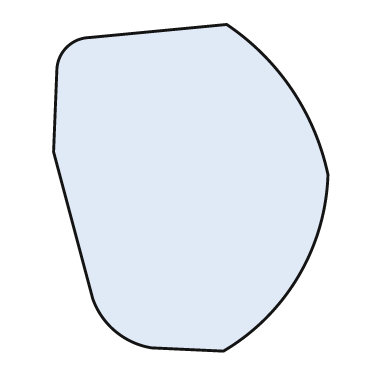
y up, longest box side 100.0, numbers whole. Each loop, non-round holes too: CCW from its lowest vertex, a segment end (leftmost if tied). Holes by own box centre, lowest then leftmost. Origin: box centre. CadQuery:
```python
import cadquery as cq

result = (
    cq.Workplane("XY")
    .moveTo(10.0, -50.0)
    .threePointArc((33.0, -27.0), (42.0, 4.0))
    .threePointArc((31.0, 30.0), (11.0, 50.0))
    .lineTo(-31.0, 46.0)
    .threePointArc((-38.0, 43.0), (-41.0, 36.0))
    .lineTo(-42.0, 11.0)
    .lineTo(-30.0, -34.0)
    .threePointArc((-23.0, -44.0), (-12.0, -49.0))
    .close()
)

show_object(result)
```